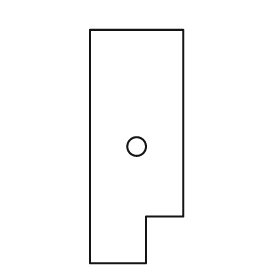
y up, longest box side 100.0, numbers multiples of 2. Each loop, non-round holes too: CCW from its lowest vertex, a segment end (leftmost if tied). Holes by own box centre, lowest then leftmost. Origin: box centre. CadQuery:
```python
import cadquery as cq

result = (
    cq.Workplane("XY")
    .moveTo(-20.0, -50.0)
    .lineTo(4.0, -50.0)
    .lineTo(4.0, -30.0)
    .lineTo(20.0, -30.0)
    .lineTo(20.0, 50.0)
    .lineTo(-20.0, 50.0)
    .close()
    .moveTo(0.0, 0.0)
    .circle(4.0)
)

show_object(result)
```